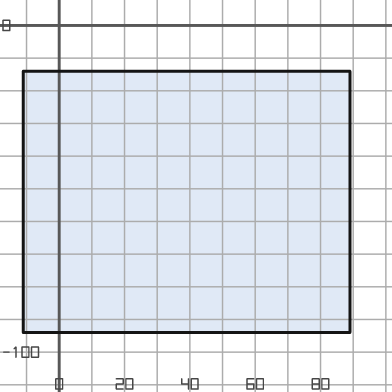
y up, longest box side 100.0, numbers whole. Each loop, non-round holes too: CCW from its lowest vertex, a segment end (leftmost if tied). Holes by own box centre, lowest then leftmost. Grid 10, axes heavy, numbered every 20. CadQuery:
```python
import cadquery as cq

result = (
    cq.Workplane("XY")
    .moveTo(-11.0, -94.0)
    .lineTo(89.0, -94.0)
    .lineTo(89.0, -14.0)
    .lineTo(-11.0, -14.0)
    .close()
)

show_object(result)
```